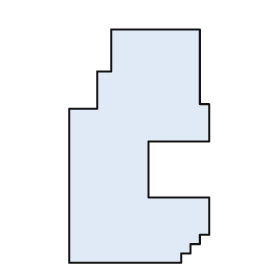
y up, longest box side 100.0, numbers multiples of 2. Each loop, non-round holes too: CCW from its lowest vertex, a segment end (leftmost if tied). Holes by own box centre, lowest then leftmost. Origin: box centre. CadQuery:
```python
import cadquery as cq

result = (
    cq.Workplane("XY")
    .moveTo(-30.0, -50.0)
    .lineTo(18.0, -50.0)
    .lineTo(18.0, -46.0)
    .lineTo(22.0, -46.0)
    .lineTo(22.0, -42.0)
    .lineTo(26.0, -42.0)
    .lineTo(26.0, -38.0)
    .lineTo(30.0, -38.0)
    .lineTo(30.0, -22.0)
    .lineTo(4.0, -22.0)
    .lineTo(4.0, 2.0)
    .lineTo(30.0, 2.0)
    .lineTo(30.0, 18.0)
    .lineTo(26.0, 18.0)
    .lineTo(26.0, 50.0)
    .lineTo(-12.0, 50.0)
    .lineTo(-12.0, 32.0)
    .lineTo(-18.0, 32.0)
    .lineTo(-18.0, 16.0)
    .lineTo(-30.0, 16.0)
    .close()
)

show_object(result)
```